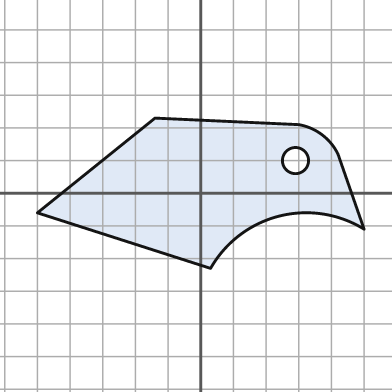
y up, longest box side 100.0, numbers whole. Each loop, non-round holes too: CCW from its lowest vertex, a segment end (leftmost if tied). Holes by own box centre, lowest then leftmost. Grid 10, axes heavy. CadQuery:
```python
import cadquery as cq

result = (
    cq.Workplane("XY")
    .moveTo(3.0, -23.0)
    .threePointArc((24.0, -7.0), (50.0, -11.0))
    .lineTo(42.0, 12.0)
    .threePointArc((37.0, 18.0), (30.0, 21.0))
    .lineTo(-14.0, 23.0)
    .lineTo(-50.0, -6.0)
    .close()
    .moveTo(29.0, 10.0)
    .circle(4.0)
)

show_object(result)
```